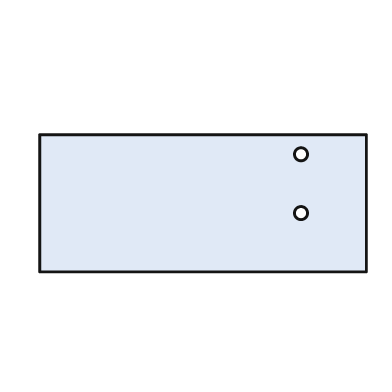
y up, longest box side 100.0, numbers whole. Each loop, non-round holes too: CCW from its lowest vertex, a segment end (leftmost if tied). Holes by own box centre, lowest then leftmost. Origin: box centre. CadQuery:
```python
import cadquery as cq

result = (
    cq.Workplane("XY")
    .moveTo(-50.0, -21.0)
    .lineTo(50.0, -21.0)
    .lineTo(50.0, 21.0)
    .lineTo(-50.0, 21.0)
    .close()
    .moveTo(30.0, -3.0)
    .circle(2.0)
    .moveTo(30.0, 15.0)
    .circle(2.0)
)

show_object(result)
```